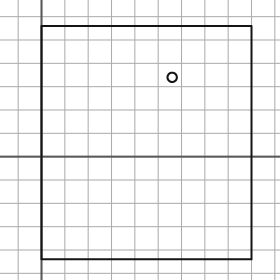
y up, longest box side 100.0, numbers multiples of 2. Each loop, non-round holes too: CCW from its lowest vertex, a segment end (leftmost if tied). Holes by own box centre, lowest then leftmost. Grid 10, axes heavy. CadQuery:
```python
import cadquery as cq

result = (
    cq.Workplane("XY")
    .moveTo(0.0, -44.0)
    .lineTo(90.0, -44.0)
    .lineTo(90.0, 56.0)
    .lineTo(0.0, 56.0)
    .close()
    .moveTo(56.0, 34.0)
    .circle(2.0)
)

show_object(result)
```